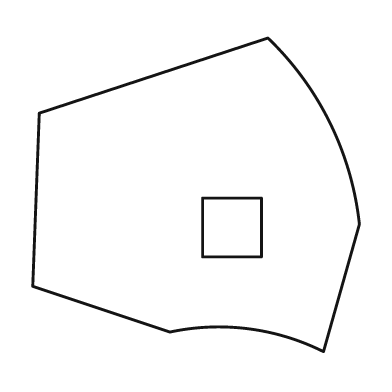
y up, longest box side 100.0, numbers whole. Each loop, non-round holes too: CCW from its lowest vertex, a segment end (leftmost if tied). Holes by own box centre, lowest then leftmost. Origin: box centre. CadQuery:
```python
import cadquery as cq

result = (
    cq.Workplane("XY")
    .moveTo(39.0, -48.0)
    .lineTo(50.0, -9.0)
    .threePointArc((41.0, 22.0), (22.0, 48.0))
    .lineTo(-48.0, 25.0)
    .lineTo(-50.0, -28.0)
    .lineTo(-8.0, -42.0)
    .threePointArc((16.0, -41.0), (39.0, -48.0))
    .close()
    .moveTo(2.0, -19.0)
    .lineTo(20.0, -19.0)
    .lineTo(20.0, -1.0)
    .lineTo(2.0, -1.0)
    .close()
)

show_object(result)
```